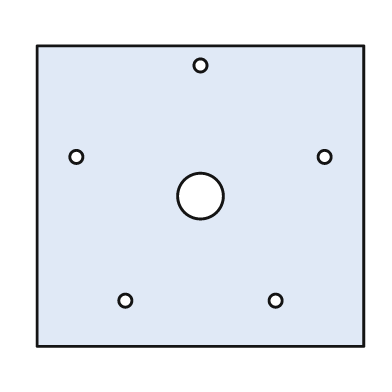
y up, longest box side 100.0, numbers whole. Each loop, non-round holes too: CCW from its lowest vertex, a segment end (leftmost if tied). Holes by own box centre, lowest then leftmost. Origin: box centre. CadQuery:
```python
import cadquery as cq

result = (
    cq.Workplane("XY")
    .moveTo(-50.0, -46.0)
    .lineTo(50.0, -46.0)
    .lineTo(50.0, 46.0)
    .lineTo(-50.0, 46.0)
    .close()
    .moveTo(-23.0, -32.0)
    .circle(2.0)
    .moveTo(23.0, -32.0)
    .circle(2.0)
    .moveTo(0.0, 0.0)
    .circle(7.0)
    .moveTo(-38.0, 12.0)
    .circle(2.0)
    .moveTo(38.0, 12.0)
    .circle(2.0)
    .moveTo(0.0, 40.0)
    .circle(2.0)
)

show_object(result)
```